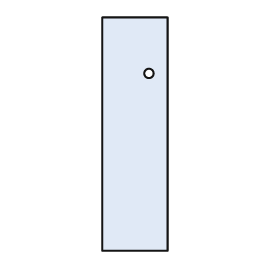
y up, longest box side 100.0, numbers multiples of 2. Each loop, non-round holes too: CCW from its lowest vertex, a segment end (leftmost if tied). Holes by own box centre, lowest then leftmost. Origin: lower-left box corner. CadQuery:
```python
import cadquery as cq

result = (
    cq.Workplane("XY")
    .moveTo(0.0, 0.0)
    .lineTo(28.0, 0.0)
    .lineTo(28.0, 100.0)
    .lineTo(0.0, 100.0)
    .close()
    .moveTo(20.0, 76.0)
    .circle(2.0)
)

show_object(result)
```